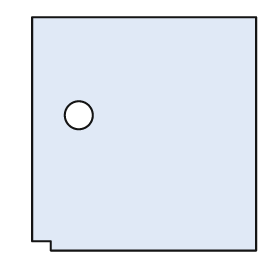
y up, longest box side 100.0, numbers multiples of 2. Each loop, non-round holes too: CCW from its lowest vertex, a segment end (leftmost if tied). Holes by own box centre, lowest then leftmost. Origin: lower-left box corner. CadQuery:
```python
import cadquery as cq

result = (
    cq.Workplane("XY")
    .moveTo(8.0, 0.0)
    .lineTo(96.0, 0.0)
    .lineTo(96.0, 100.0)
    .lineTo(0.0, 100.0)
    .lineTo(0.0, 4.0)
    .lineTo(8.0, 4.0)
    .close()
    .moveTo(20.0, 58.0)
    .circle(6.0)
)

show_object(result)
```